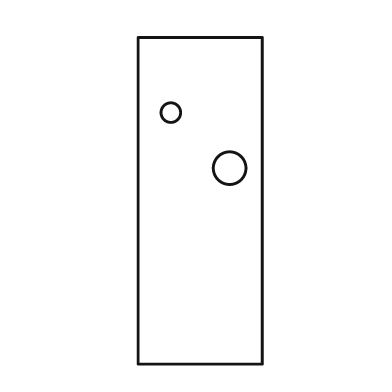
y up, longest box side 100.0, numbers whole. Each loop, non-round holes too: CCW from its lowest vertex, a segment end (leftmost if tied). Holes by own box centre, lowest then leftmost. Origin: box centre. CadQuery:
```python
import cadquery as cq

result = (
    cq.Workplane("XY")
    .moveTo(-19.0, -50.0)
    .lineTo(19.0, -50.0)
    .lineTo(19.0, 50.0)
    .lineTo(-19.0, 50.0)
    .close()
    .moveTo(9.0, 10.0)
    .circle(5.0)
    .moveTo(-9.0, 27.0)
    .circle(3.0)
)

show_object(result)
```